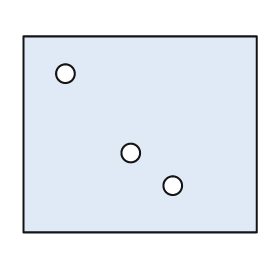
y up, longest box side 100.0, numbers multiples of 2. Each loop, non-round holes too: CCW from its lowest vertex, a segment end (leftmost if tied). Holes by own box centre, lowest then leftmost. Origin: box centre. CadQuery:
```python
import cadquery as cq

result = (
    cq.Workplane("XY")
    .moveTo(-50.0, -42.0)
    .lineTo(50.0, -42.0)
    .lineTo(50.0, 42.0)
    .lineTo(-50.0, 42.0)
    .close()
    .moveTo(14.0, -22.0)
    .circle(4.0)
    .moveTo(-4.0, -8.0)
    .circle(4.0)
    .moveTo(-32.0, 26.0)
    .circle(4.0)
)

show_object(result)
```